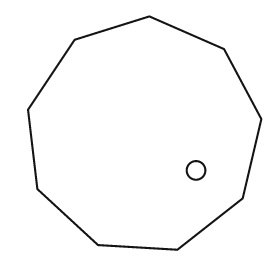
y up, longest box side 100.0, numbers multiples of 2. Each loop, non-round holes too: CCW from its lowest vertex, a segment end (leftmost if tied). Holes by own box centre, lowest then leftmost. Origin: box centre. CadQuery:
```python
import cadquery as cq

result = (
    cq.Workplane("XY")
    .moveTo(14.0, -50.0)
    .lineTo(42.0, -28.0)
    .lineTo(50.0, 6.0)
    .lineTo(34.0, 36.0)
    .lineTo(2.0, 50.0)
    .lineTo(-30.0, 40.0)
    .lineTo(-50.0, 10.0)
    .lineTo(-46.0, -24.0)
    .lineTo(-20.0, -48.0)
    .close()
    .moveTo(22.0, -16.0)
    .circle(4.0)
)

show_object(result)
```